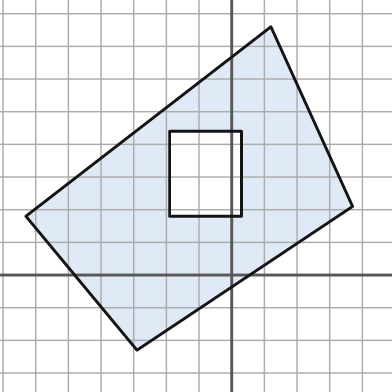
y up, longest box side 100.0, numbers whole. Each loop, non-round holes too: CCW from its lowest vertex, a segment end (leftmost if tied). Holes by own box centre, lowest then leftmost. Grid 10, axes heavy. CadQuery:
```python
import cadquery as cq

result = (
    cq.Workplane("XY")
    .moveTo(-29.0, -23.0)
    .lineTo(37.0, 21.0)
    .lineTo(12.0, 76.0)
    .lineTo(-63.0, 18.0)
    .close()
    .moveTo(-19.0, 18.0)
    .lineTo(3.0, 18.0)
    .lineTo(3.0, 44.0)
    .lineTo(-19.0, 44.0)
    .close()
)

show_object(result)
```